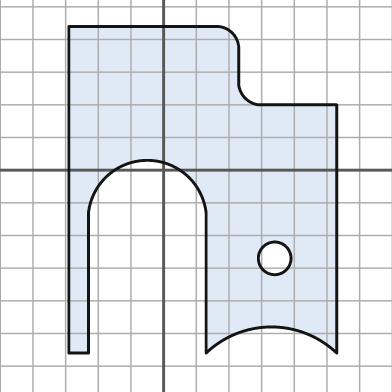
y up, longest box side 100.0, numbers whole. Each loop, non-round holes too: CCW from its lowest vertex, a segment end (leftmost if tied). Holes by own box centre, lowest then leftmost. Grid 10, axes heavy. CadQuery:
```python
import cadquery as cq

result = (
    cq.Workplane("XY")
    .moveTo(-29.0, -56.0)
    .lineTo(-23.0, -56.0)
    .lineTo(-23.0, -13.0)
    .threePointArc((-5.0, 3.0), (13.0, -13.0))
    .lineTo(13.0, -56.0)
    .threePointArc((33.0, -48.0), (53.0, -56.0))
    .lineTo(53.0, 20.0)
    .lineTo(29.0, 20.0)
    .threePointArc((25.0, 22.0), (23.0, 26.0))
    .lineTo(23.0, 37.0)
    .threePointArc((21.0, 42.0), (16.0, 44.0))
    .lineTo(-29.0, 44.0)
    .close()
    .moveTo(34.0, -27.0)
    .circle(5.0)
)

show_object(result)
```